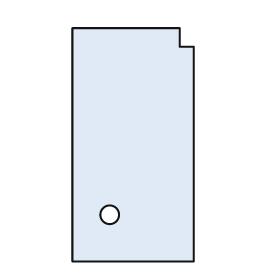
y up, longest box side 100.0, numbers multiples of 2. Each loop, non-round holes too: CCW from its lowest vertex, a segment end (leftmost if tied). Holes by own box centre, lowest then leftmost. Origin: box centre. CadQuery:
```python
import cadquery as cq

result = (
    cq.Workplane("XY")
    .moveTo(-26.0, -50.0)
    .lineTo(26.0, -50.0)
    .lineTo(26.0, 42.0)
    .lineTo(20.0, 42.0)
    .lineTo(20.0, 50.0)
    .lineTo(-26.0, 50.0)
    .close()
    .moveTo(-10.0, -30.0)
    .circle(4.0)
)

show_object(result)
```